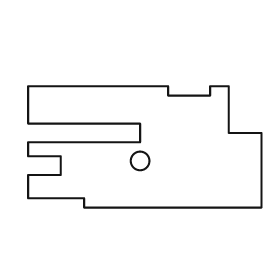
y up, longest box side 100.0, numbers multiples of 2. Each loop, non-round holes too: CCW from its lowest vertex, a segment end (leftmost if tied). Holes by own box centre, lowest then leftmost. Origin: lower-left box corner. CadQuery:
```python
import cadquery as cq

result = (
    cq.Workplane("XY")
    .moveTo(24.0, 0.0)
    .lineTo(100.0, 0.0)
    .lineTo(100.0, 32.0)
    .lineTo(86.0, 32.0)
    .lineTo(86.0, 52.0)
    .lineTo(78.0, 52.0)
    .lineTo(78.0, 48.0)
    .lineTo(60.0, 48.0)
    .lineTo(60.0, 52.0)
    .lineTo(0.0, 52.0)
    .lineTo(0.0, 36.0)
    .lineTo(48.0, 36.0)
    .lineTo(48.0, 28.0)
    .lineTo(0.0, 28.0)
    .lineTo(0.0, 22.0)
    .lineTo(14.0, 22.0)
    .lineTo(14.0, 14.0)
    .lineTo(0.0, 14.0)
    .lineTo(0.0, 4.0)
    .lineTo(24.0, 4.0)
    .close()
    .moveTo(48.0, 20.0)
    .circle(4.0)
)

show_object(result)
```